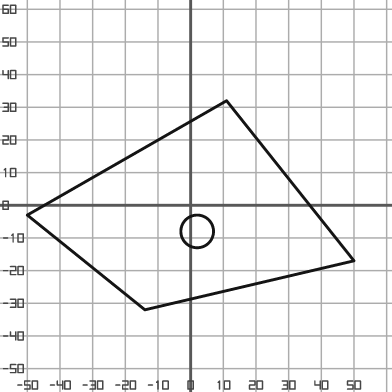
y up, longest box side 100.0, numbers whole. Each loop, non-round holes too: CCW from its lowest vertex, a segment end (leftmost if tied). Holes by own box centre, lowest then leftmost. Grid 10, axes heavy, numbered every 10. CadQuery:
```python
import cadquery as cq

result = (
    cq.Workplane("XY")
    .moveTo(-14.0, -32.0)
    .lineTo(50.0, -17.0)
    .lineTo(11.0, 32.0)
    .lineTo(-50.0, -3.0)
    .close()
    .moveTo(2.0, -8.0)
    .circle(5.0)
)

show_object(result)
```